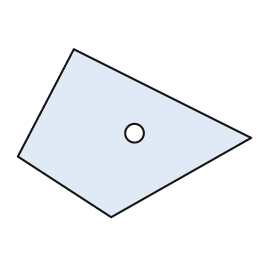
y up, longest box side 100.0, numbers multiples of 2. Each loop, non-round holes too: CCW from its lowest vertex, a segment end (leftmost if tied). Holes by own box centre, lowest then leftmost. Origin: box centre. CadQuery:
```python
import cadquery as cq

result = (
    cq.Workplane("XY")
    .moveTo(-10.0, -36.0)
    .lineTo(50.0, -2.0)
    .lineTo(-26.0, 36.0)
    .lineTo(-50.0, -10.0)
    .close()
    .moveTo(0.0, 0.0)
    .circle(4.0)
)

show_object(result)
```